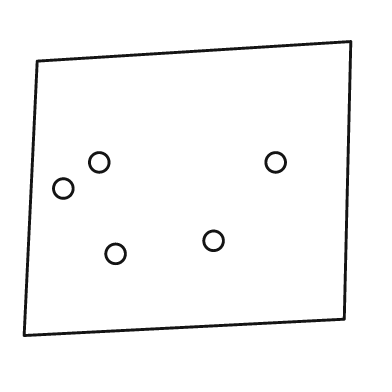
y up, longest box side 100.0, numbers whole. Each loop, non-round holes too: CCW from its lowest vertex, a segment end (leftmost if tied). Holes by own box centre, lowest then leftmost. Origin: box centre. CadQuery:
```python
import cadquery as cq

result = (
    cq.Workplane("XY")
    .moveTo(-50.0, -45.0)
    .lineTo(48.0, -40.0)
    .lineTo(50.0, 45.0)
    .lineTo(-46.0, 39.0)
    .close()
    .moveTo(-22.0, -20.0)
    .circle(3.0)
    .moveTo(8.0, -16.0)
    .circle(3.0)
    .moveTo(-38.0, 0.0)
    .circle(3.0)
    .moveTo(-27.0, 8.0)
    .circle(3.0)
    .moveTo(27.0, 8.0)
    .circle(3.0)
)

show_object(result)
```